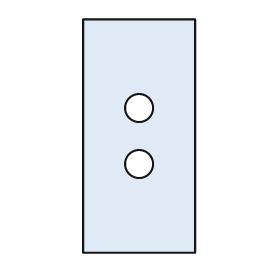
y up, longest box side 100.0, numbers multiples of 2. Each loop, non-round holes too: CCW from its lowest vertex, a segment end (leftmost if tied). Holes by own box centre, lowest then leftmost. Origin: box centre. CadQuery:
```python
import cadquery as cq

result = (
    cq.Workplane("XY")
    .moveTo(-24.0, -50.0)
    .lineTo(24.0, -50.0)
    .lineTo(24.0, 50.0)
    .lineTo(-24.0, 50.0)
    .close()
    .moveTo(0.0, -12.0)
    .circle(6.0)
    .moveTo(0.0, 12.0)
    .circle(6.0)
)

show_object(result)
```